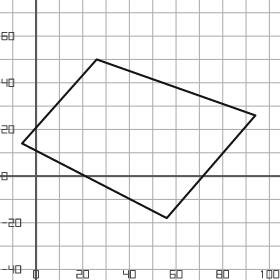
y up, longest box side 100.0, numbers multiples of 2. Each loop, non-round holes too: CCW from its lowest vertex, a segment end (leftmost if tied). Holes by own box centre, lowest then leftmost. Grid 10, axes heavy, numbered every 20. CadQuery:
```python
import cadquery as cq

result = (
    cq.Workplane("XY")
    .moveTo(56.0, -18.0)
    .lineTo(94.0, 26.0)
    .lineTo(26.0, 50.0)
    .lineTo(-6.0, 14.0)
    .close()
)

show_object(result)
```